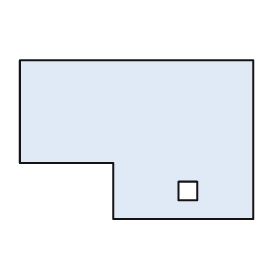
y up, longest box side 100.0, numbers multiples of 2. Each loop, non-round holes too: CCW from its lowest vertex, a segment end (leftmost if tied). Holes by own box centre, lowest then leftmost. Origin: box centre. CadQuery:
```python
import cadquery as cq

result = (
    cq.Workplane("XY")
    .moveTo(-10.0, -34.0)
    .lineTo(50.0, -34.0)
    .lineTo(50.0, 34.0)
    .lineTo(-50.0, 34.0)
    .lineTo(-50.0, -10.0)
    .lineTo(-10.0, -10.0)
    .close()
    .moveTo(18.0, -26.0)
    .lineTo(26.0, -26.0)
    .lineTo(26.0, -18.0)
    .lineTo(18.0, -18.0)
    .close()
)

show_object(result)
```